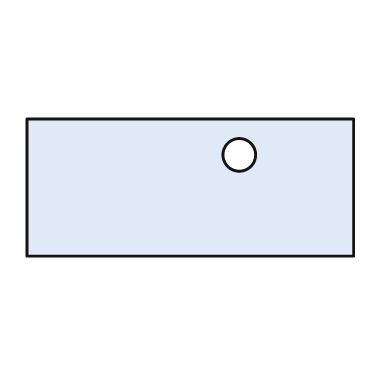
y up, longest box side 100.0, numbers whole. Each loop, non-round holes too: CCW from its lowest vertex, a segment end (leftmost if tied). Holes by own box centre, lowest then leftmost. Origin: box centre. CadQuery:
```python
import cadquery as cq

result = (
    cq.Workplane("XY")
    .moveTo(-50.0, -21.0)
    .lineTo(50.0, -21.0)
    .lineTo(50.0, 21.0)
    .lineTo(-50.0, 21.0)
    .close()
    .moveTo(15.0, 10.0)
    .circle(5.0)
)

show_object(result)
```